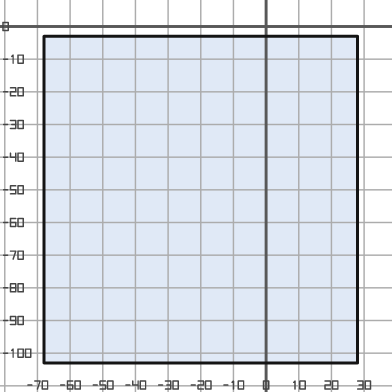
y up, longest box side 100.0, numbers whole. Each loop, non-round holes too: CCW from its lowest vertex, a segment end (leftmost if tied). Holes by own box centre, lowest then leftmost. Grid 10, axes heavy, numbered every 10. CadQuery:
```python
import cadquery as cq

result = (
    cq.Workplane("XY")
    .moveTo(-68.0, -103.0)
    .lineTo(28.0, -103.0)
    .lineTo(28.0, -3.0)
    .lineTo(-68.0, -3.0)
    .close()
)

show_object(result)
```